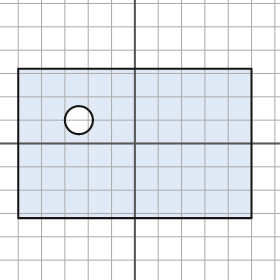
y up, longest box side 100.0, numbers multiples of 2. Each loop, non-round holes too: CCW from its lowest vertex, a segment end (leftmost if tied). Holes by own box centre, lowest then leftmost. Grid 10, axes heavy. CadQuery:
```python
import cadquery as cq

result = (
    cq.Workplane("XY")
    .moveTo(-50.0, -32.0)
    .lineTo(50.0, -32.0)
    .lineTo(50.0, 32.0)
    .lineTo(-50.0, 32.0)
    .close()
    .moveTo(-24.0, 10.0)
    .circle(6.0)
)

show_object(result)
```